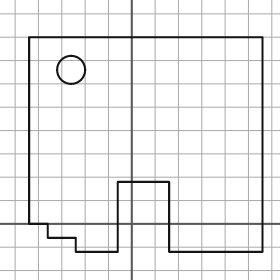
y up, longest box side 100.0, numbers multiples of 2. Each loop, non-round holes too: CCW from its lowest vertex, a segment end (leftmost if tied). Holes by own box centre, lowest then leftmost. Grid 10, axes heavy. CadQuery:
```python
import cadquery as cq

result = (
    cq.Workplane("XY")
    .moveTo(-24.0, -12.0)
    .lineTo(-6.0, -12.0)
    .lineTo(-6.0, 18.0)
    .lineTo(16.0, 18.0)
    .lineTo(16.0, -12.0)
    .lineTo(56.0, -12.0)
    .lineTo(56.0, 80.0)
    .lineTo(-44.0, 80.0)
    .lineTo(-44.0, 0.0)
    .lineTo(-36.0, 0.0)
    .lineTo(-36.0, -6.0)
    .lineTo(-24.0, -6.0)
    .close()
    .moveTo(-26.0, 66.0)
    .circle(6.0)
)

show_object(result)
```